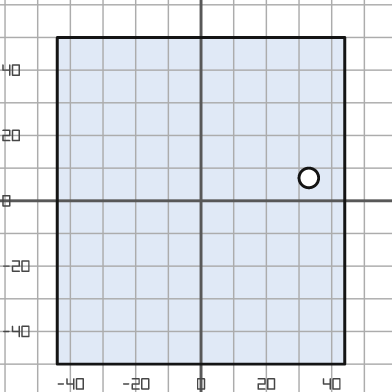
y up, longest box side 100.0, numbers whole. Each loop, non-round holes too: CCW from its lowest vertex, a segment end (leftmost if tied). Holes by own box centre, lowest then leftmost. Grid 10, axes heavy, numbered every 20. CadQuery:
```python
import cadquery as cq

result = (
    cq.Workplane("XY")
    .moveTo(-44.0, -50.0)
    .lineTo(44.0, -50.0)
    .lineTo(44.0, 50.0)
    .lineTo(-44.0, 50.0)
    .close()
    .moveTo(33.0, 7.0)
    .circle(3.0)
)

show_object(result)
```